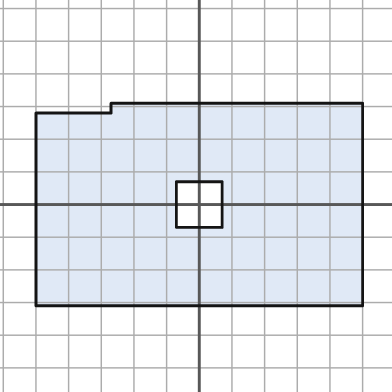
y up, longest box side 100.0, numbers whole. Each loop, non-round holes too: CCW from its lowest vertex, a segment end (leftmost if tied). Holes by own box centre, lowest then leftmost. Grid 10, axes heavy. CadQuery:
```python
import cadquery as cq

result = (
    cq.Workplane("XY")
    .moveTo(-50.0, -31.0)
    .lineTo(50.0, -31.0)
    .lineTo(50.0, 31.0)
    .lineTo(-27.0, 31.0)
    .lineTo(-27.0, 28.0)
    .lineTo(-50.0, 28.0)
    .close()
    .moveTo(-7.0, -7.0)
    .lineTo(7.0, -7.0)
    .lineTo(7.0, 7.0)
    .lineTo(-7.0, 7.0)
    .close()
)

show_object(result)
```